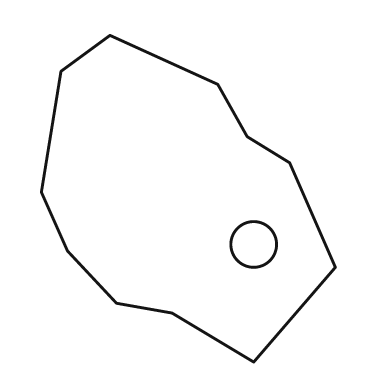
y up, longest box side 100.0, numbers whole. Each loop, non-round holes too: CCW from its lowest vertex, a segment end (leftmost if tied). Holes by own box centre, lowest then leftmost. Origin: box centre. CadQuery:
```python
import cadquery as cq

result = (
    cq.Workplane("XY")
    .moveTo(20.0, -50.0)
    .lineTo(45.0, -21.0)
    .lineTo(31.0, 11.0)
    .lineTo(18.0, 19.0)
    .lineTo(9.0, 35.0)
    .lineTo(-24.0, 50.0)
    .lineTo(-39.0, 39.0)
    .lineTo(-45.0, 2.0)
    .lineTo(-37.0, -16.0)
    .lineTo(-22.0, -32.0)
    .lineTo(-5.0, -35.0)
    .close()
    .moveTo(20.0, -14.0)
    .circle(7.0)
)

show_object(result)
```